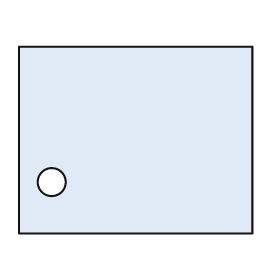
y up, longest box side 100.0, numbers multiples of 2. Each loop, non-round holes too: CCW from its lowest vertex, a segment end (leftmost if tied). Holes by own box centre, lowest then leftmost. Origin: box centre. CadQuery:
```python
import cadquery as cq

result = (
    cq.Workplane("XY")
    .moveTo(-50.0, -40.0)
    .lineTo(50.0, -40.0)
    .lineTo(50.0, 40.0)
    .lineTo(-50.0, 40.0)
    .close()
    .moveTo(-36.0, -18.0)
    .circle(6.0)
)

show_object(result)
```